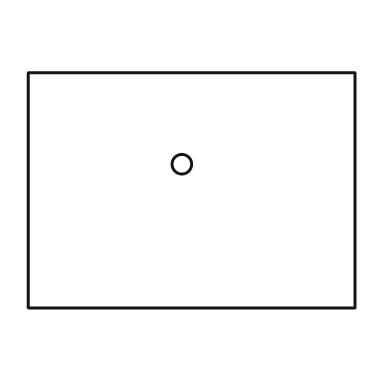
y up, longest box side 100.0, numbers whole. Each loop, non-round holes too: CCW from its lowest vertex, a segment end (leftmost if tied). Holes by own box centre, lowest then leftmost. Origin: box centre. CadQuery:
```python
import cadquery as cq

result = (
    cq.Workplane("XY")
    .moveTo(-50.0, -36.0)
    .lineTo(50.0, -36.0)
    .lineTo(50.0, 36.0)
    .lineTo(-50.0, 36.0)
    .close()
    .moveTo(-3.0, 8.0)
    .circle(3.0)
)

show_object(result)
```